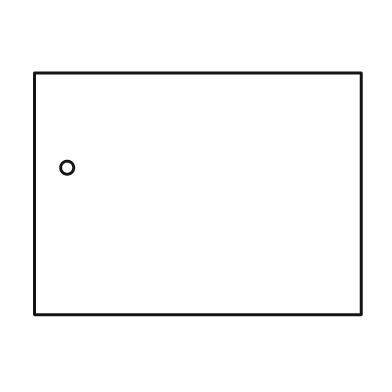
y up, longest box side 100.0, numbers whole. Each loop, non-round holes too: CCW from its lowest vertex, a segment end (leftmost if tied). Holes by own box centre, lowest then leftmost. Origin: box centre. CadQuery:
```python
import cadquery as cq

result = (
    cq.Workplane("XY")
    .moveTo(-50.0, -37.0)
    .lineTo(50.0, -37.0)
    .lineTo(50.0, 37.0)
    .lineTo(-50.0, 37.0)
    .close()
    .moveTo(-40.0, 8.0)
    .circle(2.0)
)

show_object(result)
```